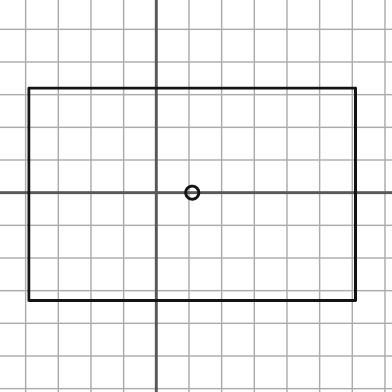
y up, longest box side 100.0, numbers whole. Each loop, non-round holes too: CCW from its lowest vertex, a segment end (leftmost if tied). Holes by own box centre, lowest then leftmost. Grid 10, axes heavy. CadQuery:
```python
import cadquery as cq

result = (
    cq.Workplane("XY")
    .moveTo(-39.0, -33.0)
    .lineTo(61.0, -33.0)
    .lineTo(61.0, 32.0)
    .lineTo(-39.0, 32.0)
    .close()
    .moveTo(11.0, 0.0)
    .circle(2.0)
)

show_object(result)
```